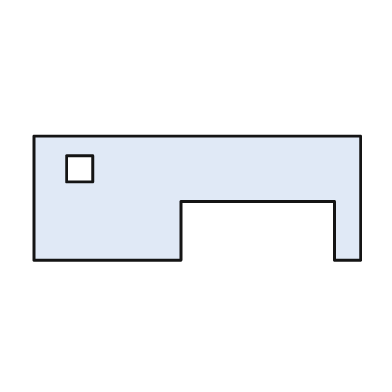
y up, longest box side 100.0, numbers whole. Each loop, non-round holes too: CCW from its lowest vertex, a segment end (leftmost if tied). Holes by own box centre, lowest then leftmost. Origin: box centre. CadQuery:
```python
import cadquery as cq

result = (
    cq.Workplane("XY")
    .moveTo(-50.0, -19.0)
    .lineTo(-5.0, -19.0)
    .lineTo(-5.0, -1.0)
    .lineTo(42.0, -1.0)
    .lineTo(42.0, -19.0)
    .lineTo(50.0, -19.0)
    .lineTo(50.0, 19.0)
    .lineTo(-50.0, 19.0)
    .close()
    .moveTo(-40.0, 5.0)
    .lineTo(-32.0, 5.0)
    .lineTo(-32.0, 13.0)
    .lineTo(-40.0, 13.0)
    .close()
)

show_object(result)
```